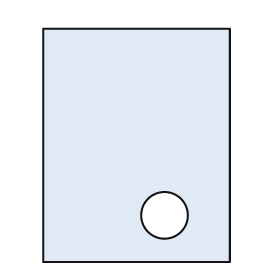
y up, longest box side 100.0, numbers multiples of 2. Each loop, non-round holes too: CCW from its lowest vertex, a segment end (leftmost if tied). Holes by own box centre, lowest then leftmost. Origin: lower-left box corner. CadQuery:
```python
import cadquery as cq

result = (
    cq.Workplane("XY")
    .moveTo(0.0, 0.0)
    .lineTo(80.0, 0.0)
    .lineTo(80.0, 100.0)
    .lineTo(0.0, 100.0)
    .close()
    .moveTo(52.0, 20.0)
    .circle(10.0)
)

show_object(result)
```